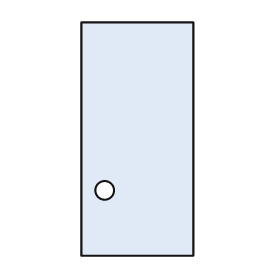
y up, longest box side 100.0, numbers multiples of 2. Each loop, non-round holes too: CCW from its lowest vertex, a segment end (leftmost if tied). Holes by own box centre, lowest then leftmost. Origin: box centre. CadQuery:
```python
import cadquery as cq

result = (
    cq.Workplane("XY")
    .moveTo(-24.0, -50.0)
    .lineTo(24.0, -50.0)
    .lineTo(24.0, 50.0)
    .lineTo(-24.0, 50.0)
    .close()
    .moveTo(-14.0, -22.0)
    .circle(4.0)
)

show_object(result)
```